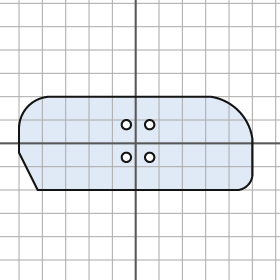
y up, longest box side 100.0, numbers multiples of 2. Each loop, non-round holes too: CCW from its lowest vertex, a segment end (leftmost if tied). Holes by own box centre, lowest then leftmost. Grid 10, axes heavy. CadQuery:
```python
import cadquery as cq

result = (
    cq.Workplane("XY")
    .moveTo(-42.0, -20.0)
    .lineTo(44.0, -20.0)
    .threePointArc((48.0, -18.0), (50.0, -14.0))
    .lineTo(50.0, 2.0)
    .threePointArc((44.0, 14.0), (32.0, 20.0))
    .lineTo(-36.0, 20.0)
    .threePointArc((-46.0, 16.0), (-50.0, 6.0))
    .lineTo(-50.0, -4.0)
    .close()
    .moveTo(-4.0, -6.0)
    .circle(2.0)
    .moveTo(6.0, -6.0)
    .circle(2.0)
    .moveTo(-4.0, 8.0)
    .circle(2.0)
    .moveTo(6.0, 8.0)
    .circle(2.0)
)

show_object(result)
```